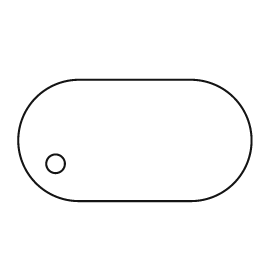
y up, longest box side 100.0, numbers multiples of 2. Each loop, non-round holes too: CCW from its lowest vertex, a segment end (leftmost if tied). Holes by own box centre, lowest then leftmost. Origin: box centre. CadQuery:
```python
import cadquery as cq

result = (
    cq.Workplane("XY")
    .moveTo(-24.0, -26.0)
    .lineTo(24.0, -26.0)
    .threePointArc((50.0, 0.0), (24.0, 26.0))
    .lineTo(-24.0, 26.0)
    .threePointArc((-50.0, 0.0), (-24.0, -26.0))
    .close()
    .moveTo(-34.0, -10.0)
    .circle(4.0)
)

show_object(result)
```